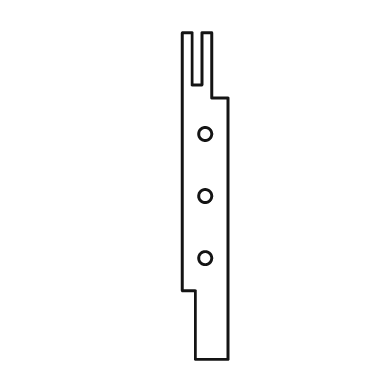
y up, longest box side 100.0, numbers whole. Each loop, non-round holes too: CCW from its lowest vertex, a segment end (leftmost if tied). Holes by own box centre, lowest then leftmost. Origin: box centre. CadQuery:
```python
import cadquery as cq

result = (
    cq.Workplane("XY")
    .moveTo(-3.0, -50.0)
    .lineTo(7.0, -50.0)
    .lineTo(7.0, 30.0)
    .lineTo(2.0, 30.0)
    .lineTo(2.0, 50.0)
    .lineTo(-1.0, 50.0)
    .lineTo(-1.0, 34.0)
    .lineTo(-4.0, 34.0)
    .lineTo(-4.0, 50.0)
    .lineTo(-7.0, 50.0)
    .lineTo(-7.0, -29.0)
    .lineTo(-3.0, -29.0)
    .close()
    .moveTo(0.0, -19.0)
    .circle(2.0)
    .moveTo(0.0, 0.0)
    .circle(2.0)
    .moveTo(0.0, 19.0)
    .circle(2.0)
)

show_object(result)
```